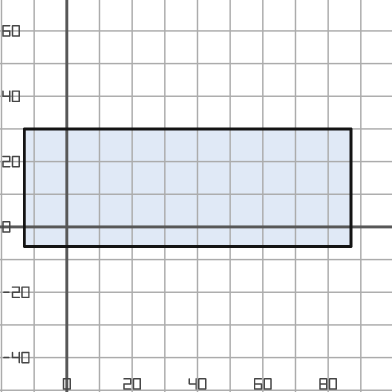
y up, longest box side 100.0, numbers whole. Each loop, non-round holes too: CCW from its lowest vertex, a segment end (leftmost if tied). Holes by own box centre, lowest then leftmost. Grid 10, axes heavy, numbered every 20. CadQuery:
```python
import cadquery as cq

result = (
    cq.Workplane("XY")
    .moveTo(-13.0, -6.0)
    .lineTo(87.0, -6.0)
    .lineTo(87.0, 30.0)
    .lineTo(-13.0, 30.0)
    .close()
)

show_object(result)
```